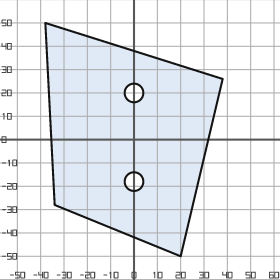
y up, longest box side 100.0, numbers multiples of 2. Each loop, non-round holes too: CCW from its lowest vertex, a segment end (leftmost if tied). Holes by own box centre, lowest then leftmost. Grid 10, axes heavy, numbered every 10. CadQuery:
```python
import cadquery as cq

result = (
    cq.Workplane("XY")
    .moveTo(20.0, -50.0)
    .lineTo(38.0, 26.0)
    .lineTo(-38.0, 50.0)
    .lineTo(-34.0, -28.0)
    .close()
    .moveTo(0.0, -18.0)
    .circle(4.0)
    .moveTo(0.0, 20.0)
    .circle(4.0)
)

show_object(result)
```